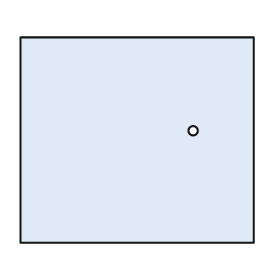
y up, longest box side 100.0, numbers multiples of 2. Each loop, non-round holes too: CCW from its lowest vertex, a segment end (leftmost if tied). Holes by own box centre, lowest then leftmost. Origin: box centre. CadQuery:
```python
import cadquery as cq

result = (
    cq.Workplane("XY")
    .moveTo(-50.0, -44.0)
    .lineTo(50.0, -44.0)
    .lineTo(50.0, 44.0)
    .lineTo(-50.0, 44.0)
    .close()
    .moveTo(24.0, 4.0)
    .circle(2.0)
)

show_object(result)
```